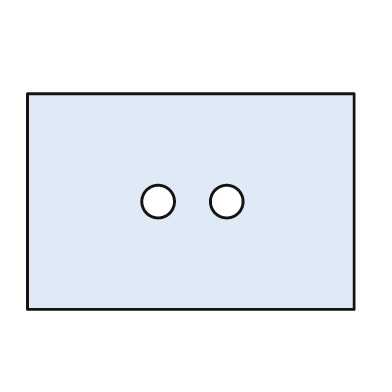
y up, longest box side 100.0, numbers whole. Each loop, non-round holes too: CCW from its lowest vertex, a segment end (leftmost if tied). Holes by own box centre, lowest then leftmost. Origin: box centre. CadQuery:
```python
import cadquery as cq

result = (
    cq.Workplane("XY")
    .moveTo(-50.0, -33.0)
    .lineTo(50.0, -33.0)
    .lineTo(50.0, 33.0)
    .lineTo(-50.0, 33.0)
    .close()
    .moveTo(-10.0, 0.0)
    .circle(5.0)
    .moveTo(11.0, 0.0)
    .circle(5.0)
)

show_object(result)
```